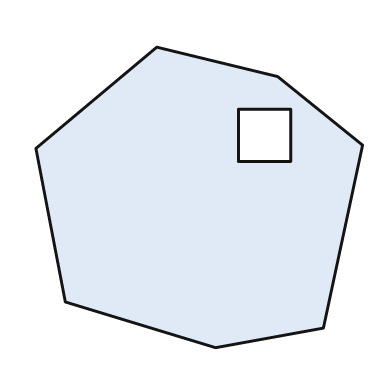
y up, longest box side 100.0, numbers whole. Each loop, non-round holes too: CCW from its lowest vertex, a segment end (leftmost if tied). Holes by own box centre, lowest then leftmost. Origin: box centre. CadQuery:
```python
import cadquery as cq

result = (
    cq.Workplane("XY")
    .moveTo(5.0, -46.0)
    .lineTo(38.0, -40.0)
    .lineTo(50.0, 16.0)
    .lineTo(24.0, 37.0)
    .lineTo(-13.0, 46.0)
    .lineTo(-50.0, 15.0)
    .lineTo(-41.0, -32.0)
    .close()
    .moveTo(12.0, 11.0)
    .lineTo(28.0, 11.0)
    .lineTo(28.0, 27.0)
    .lineTo(12.0, 27.0)
    .close()
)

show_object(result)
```